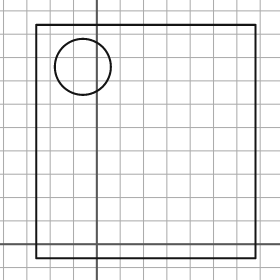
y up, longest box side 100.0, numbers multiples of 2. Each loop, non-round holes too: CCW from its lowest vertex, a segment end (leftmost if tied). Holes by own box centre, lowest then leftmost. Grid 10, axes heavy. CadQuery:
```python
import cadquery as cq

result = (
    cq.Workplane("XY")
    .moveTo(-26.0, -6.0)
    .lineTo(68.0, -6.0)
    .lineTo(68.0, 94.0)
    .lineTo(-26.0, 94.0)
    .close()
    .moveTo(-6.0, 76.0)
    .circle(12.0)
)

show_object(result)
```